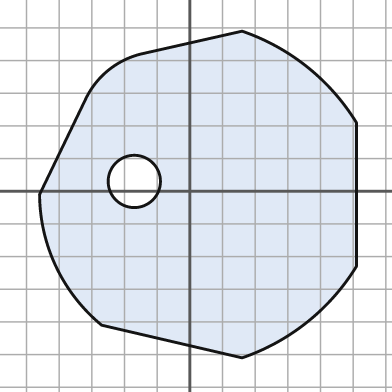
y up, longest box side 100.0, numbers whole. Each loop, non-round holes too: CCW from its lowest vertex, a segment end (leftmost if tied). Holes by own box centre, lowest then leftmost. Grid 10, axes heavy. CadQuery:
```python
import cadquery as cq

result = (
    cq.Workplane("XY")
    .moveTo(16.0, -51.0)
    .threePointArc((36.0, -40.0), (51.0, -23.0))
    .lineTo(51.0, 21.0)
    .threePointArc((36.0, 38.0), (16.0, 49.0))
    .lineTo(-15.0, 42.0)
    .threePointArc((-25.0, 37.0), (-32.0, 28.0))
    .lineTo(-46.0, -1.0)
    .threePointArc((-41.0, -23.0), (-27.0, -41.0))
    .close()
    .moveTo(-17.0, 3.0)
    .circle(8.0)
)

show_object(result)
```